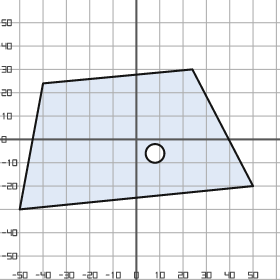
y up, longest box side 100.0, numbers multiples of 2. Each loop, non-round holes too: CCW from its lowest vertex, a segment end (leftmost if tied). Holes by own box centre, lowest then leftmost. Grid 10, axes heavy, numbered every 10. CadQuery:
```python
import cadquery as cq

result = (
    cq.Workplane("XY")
    .moveTo(-50.0, -30.0)
    .lineTo(50.0, -20.0)
    .lineTo(24.0, 30.0)
    .lineTo(-40.0, 24.0)
    .close()
    .moveTo(8.0, -6.0)
    .circle(4.0)
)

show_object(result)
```